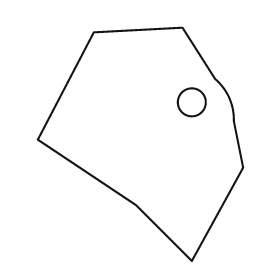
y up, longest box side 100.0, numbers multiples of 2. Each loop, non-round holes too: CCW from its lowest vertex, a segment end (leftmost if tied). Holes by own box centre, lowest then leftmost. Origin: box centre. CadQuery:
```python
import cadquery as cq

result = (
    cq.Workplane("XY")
    .moveTo(22.0, -50.0)
    .lineTo(44.0, -10.0)
    .lineTo(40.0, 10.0)
    .threePointArc((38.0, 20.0), (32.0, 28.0))
    .lineTo(18.0, 50.0)
    .lineTo(-20.0, 48.0)
    .lineTo(-44.0, 2.0)
    .lineTo(-2.0, -26.0)
    .close()
    .moveTo(22.0, 18.0)
    .circle(6.0)
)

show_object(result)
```